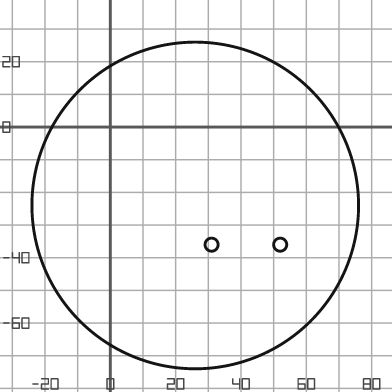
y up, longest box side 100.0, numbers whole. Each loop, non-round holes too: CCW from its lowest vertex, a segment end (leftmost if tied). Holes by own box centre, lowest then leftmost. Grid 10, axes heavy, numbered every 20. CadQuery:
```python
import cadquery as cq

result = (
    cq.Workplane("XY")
    .moveTo(26.0, -24.0)
    .circle(50.0)
    .moveTo(31.0, -36.0)
    .circle(2.0)
    .moveTo(52.0, -36.0)
    .circle(2.0)
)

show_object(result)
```